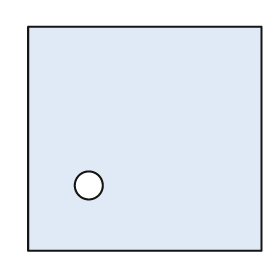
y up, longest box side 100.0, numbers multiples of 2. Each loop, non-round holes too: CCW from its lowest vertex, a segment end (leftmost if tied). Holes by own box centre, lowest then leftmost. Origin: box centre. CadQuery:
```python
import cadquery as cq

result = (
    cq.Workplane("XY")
    .moveTo(-50.0, -48.0)
    .lineTo(50.0, -48.0)
    .lineTo(50.0, 48.0)
    .lineTo(-50.0, 48.0)
    .close()
    .moveTo(-24.0, -20.0)
    .circle(6.0)
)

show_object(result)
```